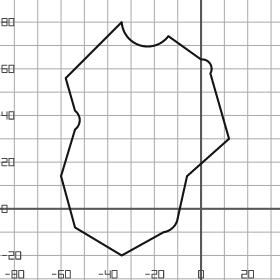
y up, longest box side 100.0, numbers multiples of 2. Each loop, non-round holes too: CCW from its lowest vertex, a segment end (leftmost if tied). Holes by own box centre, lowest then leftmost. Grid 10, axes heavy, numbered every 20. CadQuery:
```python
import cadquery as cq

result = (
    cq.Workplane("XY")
    .moveTo(-34.0, -20.0)
    .lineTo(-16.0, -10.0)
    .threePointArc((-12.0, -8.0), (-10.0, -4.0))
    .lineTo(-6.0, 14.0)
    .lineTo(12.0, 30.0)
    .lineTo(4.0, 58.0)
    .threePointArc((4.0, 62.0), (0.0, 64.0))
    .lineTo(-14.0, 74.0)
    .threePointArc((-26.0, 70.0), (-34.0, 80.0))
    .lineTo(-58.0, 56.0)
    .lineTo(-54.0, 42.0)
    .threePointArc((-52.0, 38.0), (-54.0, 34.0))
    .lineTo(-60.0, 14.0)
    .lineTo(-54.0, -8.0)
    .close()
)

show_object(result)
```